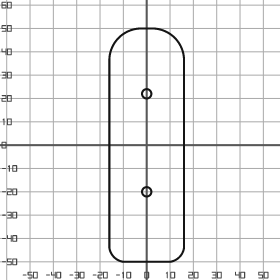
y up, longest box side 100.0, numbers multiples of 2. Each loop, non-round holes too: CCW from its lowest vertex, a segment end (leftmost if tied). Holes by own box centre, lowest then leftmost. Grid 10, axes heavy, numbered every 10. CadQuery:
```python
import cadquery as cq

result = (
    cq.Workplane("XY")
    .moveTo(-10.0, -50.0)
    .lineTo(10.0, -50.0)
    .threePointArc((14.0, -48.0), (16.0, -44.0))
    .lineTo(16.0, 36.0)
    .threePointArc((12.0, 46.0), (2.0, 50.0))
    .lineTo(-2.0, 50.0)
    .threePointArc((-12.0, 46.0), (-16.0, 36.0))
    .lineTo(-16.0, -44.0)
    .threePointArc((-14.0, -48.0), (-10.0, -50.0))
    .close()
    .moveTo(0.0, -20.0)
    .circle(2.0)
    .moveTo(0.0, 22.0)
    .circle(2.0)
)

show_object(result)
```